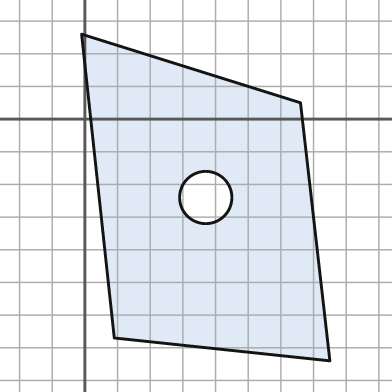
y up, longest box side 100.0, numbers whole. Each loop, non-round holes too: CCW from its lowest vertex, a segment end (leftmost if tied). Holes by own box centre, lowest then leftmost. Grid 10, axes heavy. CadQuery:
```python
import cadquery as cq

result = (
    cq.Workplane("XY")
    .moveTo(75.0, -74.0)
    .lineTo(66.0, 5.0)
    .lineTo(-1.0, 26.0)
    .lineTo(9.0, -67.0)
    .close()
    .moveTo(37.0, -24.0)
    .circle(8.0)
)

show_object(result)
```